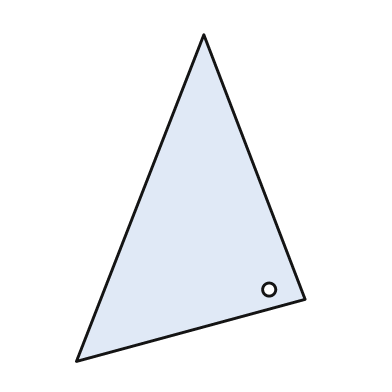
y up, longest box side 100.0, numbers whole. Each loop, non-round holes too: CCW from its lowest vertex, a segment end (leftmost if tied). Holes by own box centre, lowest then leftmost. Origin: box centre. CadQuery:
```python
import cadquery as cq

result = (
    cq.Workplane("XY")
    .moveTo(-35.0, -50.0)
    .lineTo(35.0, -31.0)
    .lineTo(4.0, 50.0)
    .close()
    .moveTo(24.0, -28.0)
    .circle(2.0)
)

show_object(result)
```